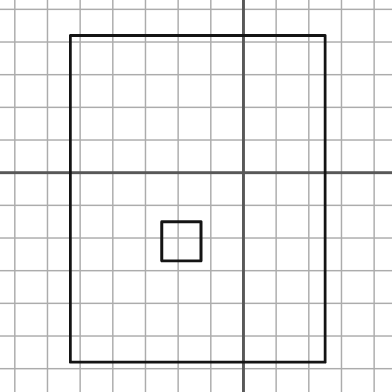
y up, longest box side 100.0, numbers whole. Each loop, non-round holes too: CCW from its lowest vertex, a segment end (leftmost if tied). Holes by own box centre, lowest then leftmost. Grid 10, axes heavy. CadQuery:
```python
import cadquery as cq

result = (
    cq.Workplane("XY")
    .moveTo(-53.0, -58.0)
    .lineTo(25.0, -58.0)
    .lineTo(25.0, 42.0)
    .lineTo(-53.0, 42.0)
    .close()
    .moveTo(-25.0, -27.0)
    .lineTo(-13.0, -27.0)
    .lineTo(-13.0, -15.0)
    .lineTo(-25.0, -15.0)
    .close()
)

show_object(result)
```